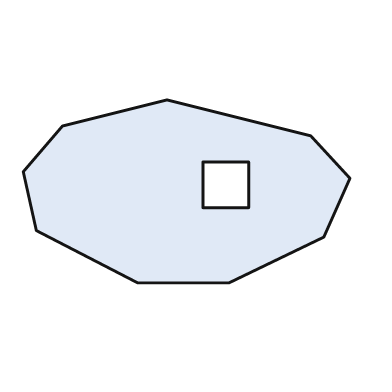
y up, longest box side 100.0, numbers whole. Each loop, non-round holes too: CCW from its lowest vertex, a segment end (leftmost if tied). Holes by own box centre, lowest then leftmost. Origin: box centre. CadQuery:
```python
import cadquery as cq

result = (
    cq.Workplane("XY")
    .moveTo(-15.0, -28.0)
    .lineTo(13.0, -28.0)
    .lineTo(42.0, -14.0)
    .lineTo(50.0, 4.0)
    .lineTo(38.0, 17.0)
    .lineTo(-6.0, 28.0)
    .lineTo(-38.0, 20.0)
    .lineTo(-50.0, 6.0)
    .lineTo(-46.0, -12.0)
    .close()
    .moveTo(5.0, -5.0)
    .lineTo(19.0, -5.0)
    .lineTo(19.0, 9.0)
    .lineTo(5.0, 9.0)
    .close()
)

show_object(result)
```